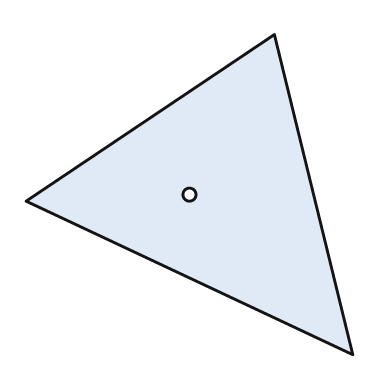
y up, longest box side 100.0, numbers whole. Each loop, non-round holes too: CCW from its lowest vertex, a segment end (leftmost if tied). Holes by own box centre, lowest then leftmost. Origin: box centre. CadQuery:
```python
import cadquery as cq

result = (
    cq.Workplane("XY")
    .moveTo(50.0, -49.0)
    .lineTo(26.0, 49.0)
    .lineTo(-50.0, -2.0)
    .close()
    .moveTo(0.0, 0.0)
    .circle(2.0)
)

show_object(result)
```